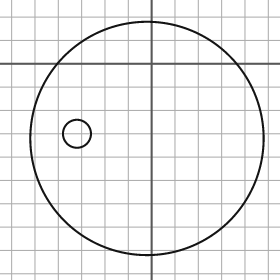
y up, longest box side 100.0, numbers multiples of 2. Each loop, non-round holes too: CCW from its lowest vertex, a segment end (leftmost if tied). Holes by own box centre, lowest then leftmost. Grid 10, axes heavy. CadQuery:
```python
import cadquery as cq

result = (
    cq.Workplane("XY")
    .moveTo(-2.0, -32.0)
    .circle(50.0)
    .moveTo(-32.0, -30.0)
    .circle(6.0)
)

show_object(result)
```